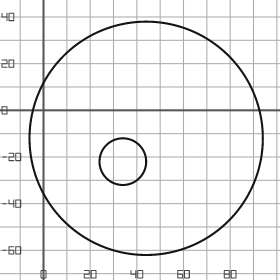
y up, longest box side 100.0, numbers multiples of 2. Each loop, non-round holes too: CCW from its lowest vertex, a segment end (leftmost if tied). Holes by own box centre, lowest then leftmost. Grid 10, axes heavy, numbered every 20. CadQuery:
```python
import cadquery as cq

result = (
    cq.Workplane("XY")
    .moveTo(44.0, -12.0)
    .circle(50.0)
    .moveTo(34.0, -22.0)
    .circle(10.0)
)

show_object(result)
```